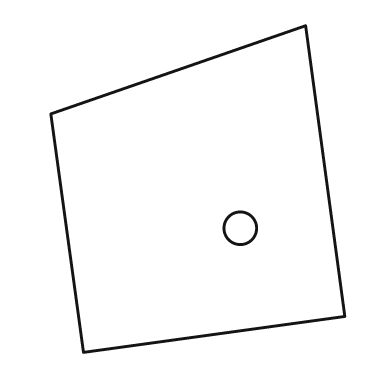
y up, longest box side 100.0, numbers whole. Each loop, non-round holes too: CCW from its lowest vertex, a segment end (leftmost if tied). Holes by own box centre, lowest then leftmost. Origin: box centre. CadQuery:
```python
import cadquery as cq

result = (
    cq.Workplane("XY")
    .moveTo(-35.0, -50.0)
    .lineTo(45.0, -39.0)
    .lineTo(33.0, 50.0)
    .lineTo(-45.0, 23.0)
    .close()
    .moveTo(13.0, -12.0)
    .circle(5.0)
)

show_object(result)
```